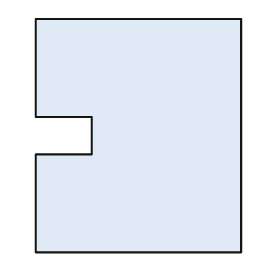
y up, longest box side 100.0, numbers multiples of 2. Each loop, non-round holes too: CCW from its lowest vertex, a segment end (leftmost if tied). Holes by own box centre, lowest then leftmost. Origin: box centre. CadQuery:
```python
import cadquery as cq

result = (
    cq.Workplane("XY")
    .moveTo(-44.0, -50.0)
    .lineTo(44.0, -50.0)
    .lineTo(44.0, 50.0)
    .lineTo(-44.0, 50.0)
    .lineTo(-44.0, 8.0)
    .lineTo(-20.0, 8.0)
    .lineTo(-20.0, -8.0)
    .lineTo(-44.0, -8.0)
    .close()
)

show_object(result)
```